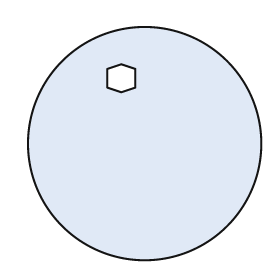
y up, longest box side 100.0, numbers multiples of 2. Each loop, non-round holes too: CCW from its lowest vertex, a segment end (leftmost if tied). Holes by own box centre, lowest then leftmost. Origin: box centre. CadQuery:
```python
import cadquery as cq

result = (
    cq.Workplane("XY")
    .moveTo(0.0, 0.0)
    .circle(50.0)
    .moveTo(-10.0, 22.0)
    .lineTo(-4.0, 24.0)
    .lineTo(-4.0, 32.0)
    .lineTo(-10.0, 34.0)
    .lineTo(-16.0, 32.0)
    .lineTo(-16.0, 24.0)
    .close()
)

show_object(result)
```